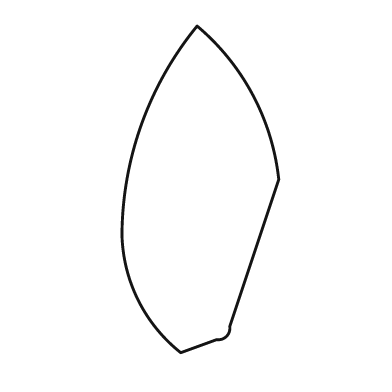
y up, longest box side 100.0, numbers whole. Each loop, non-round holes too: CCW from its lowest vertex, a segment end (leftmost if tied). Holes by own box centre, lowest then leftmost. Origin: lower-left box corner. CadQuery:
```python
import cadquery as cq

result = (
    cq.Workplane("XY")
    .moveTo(18.0, 0.0)
    .lineTo(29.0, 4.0)
    .threePointArc((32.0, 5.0), (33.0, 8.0))
    .lineTo(48.0, 53.0)
    .threePointArc((40.0, 79.0), (23.0, 100.0))
    .threePointArc((6.0, 70.0), (0.0, 36.0))
    .threePointArc((5.0, 16.0), (18.0, 0.0))
    .close()
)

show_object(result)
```